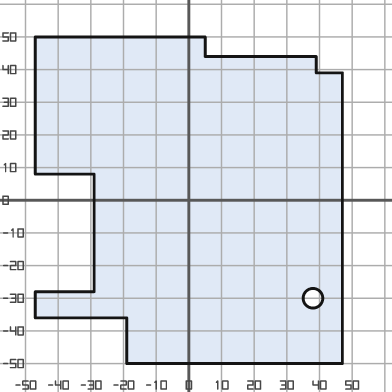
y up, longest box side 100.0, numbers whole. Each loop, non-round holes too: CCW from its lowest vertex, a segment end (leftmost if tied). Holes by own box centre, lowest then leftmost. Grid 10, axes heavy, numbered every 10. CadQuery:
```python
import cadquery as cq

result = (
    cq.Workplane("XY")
    .moveTo(-19.0, -50.0)
    .lineTo(47.0, -50.0)
    .lineTo(47.0, 39.0)
    .lineTo(39.0, 39.0)
    .lineTo(39.0, 44.0)
    .lineTo(5.0, 44.0)
    .lineTo(5.0, 50.0)
    .lineTo(-47.0, 50.0)
    .lineTo(-47.0, 8.0)
    .lineTo(-29.0, 8.0)
    .lineTo(-29.0, -28.0)
    .lineTo(-47.0, -28.0)
    .lineTo(-47.0, -36.0)
    .lineTo(-19.0, -36.0)
    .close()
    .moveTo(38.0, -30.0)
    .circle(3.0)
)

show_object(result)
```